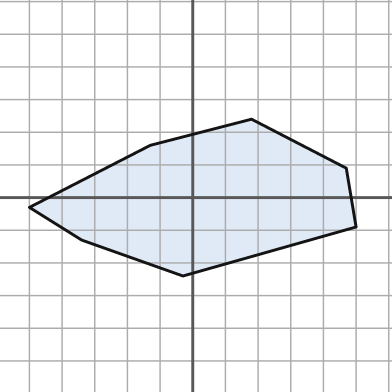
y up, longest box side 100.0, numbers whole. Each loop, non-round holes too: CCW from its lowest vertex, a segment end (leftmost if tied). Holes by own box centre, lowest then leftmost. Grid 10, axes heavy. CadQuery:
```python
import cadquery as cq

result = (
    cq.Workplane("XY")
    .moveTo(-3.0, -24.0)
    .lineTo(50.0, -9.0)
    .lineTo(47.0, 9.0)
    .lineTo(18.0, 24.0)
    .lineTo(-13.0, 16.0)
    .lineTo(-50.0, -3.0)
    .lineTo(-34.0, -13.0)
    .close()
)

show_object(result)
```